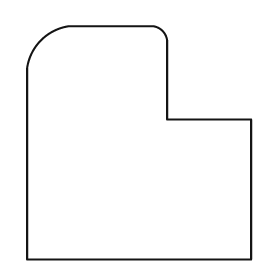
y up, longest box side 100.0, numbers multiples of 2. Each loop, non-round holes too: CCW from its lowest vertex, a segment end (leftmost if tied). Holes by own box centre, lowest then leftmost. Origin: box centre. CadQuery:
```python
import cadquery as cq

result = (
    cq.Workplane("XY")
    .moveTo(-48.0, -50.0)
    .lineTo(48.0, -50.0)
    .lineTo(48.0, 10.0)
    .lineTo(12.0, 10.0)
    .lineTo(12.0, 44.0)
    .threePointArc((10.0, 48.0), (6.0, 50.0))
    .lineTo(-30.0, 50.0)
    .threePointArc((-42.0, 44.0), (-48.0, 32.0))
    .close()
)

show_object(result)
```